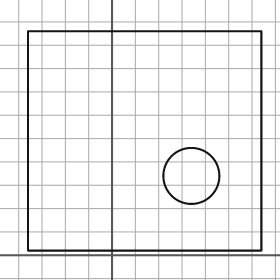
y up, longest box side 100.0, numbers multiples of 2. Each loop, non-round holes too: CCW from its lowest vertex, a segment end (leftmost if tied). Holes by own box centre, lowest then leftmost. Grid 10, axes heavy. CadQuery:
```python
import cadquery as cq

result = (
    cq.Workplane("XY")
    .moveTo(-36.0, 2.0)
    .lineTo(64.0, 2.0)
    .lineTo(64.0, 96.0)
    .lineTo(-36.0, 96.0)
    .close()
    .moveTo(34.0, 34.0)
    .circle(12.0)
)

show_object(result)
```